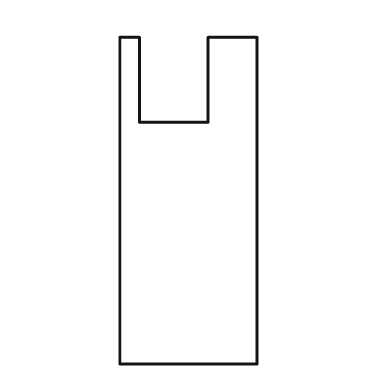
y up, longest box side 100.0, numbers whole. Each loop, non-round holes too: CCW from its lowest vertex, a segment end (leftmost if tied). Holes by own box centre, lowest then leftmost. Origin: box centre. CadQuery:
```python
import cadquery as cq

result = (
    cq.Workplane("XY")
    .moveTo(-21.0, -50.0)
    .lineTo(21.0, -50.0)
    .lineTo(21.0, 50.0)
    .lineTo(6.0, 50.0)
    .lineTo(6.0, 24.0)
    .lineTo(-15.0, 24.0)
    .lineTo(-15.0, 50.0)
    .lineTo(-21.0, 50.0)
    .close()
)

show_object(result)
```